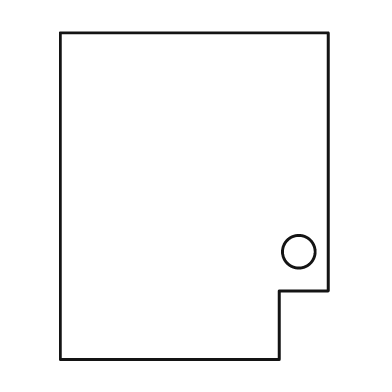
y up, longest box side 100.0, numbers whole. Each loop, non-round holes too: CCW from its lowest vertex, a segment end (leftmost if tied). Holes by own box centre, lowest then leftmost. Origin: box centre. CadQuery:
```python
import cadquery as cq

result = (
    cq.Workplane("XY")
    .moveTo(-41.0, -50.0)
    .lineTo(26.0, -50.0)
    .lineTo(26.0, -29.0)
    .lineTo(41.0, -29.0)
    .lineTo(41.0, 50.0)
    .lineTo(-41.0, 50.0)
    .close()
    .moveTo(32.0, -17.0)
    .circle(5.0)
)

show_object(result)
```